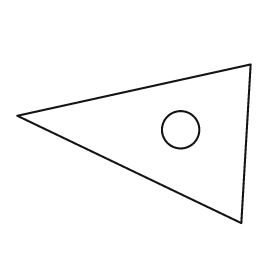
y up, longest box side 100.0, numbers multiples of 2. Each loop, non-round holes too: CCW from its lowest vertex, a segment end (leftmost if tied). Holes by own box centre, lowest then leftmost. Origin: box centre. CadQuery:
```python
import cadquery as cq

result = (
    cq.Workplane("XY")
    .moveTo(46.0, -34.0)
    .lineTo(50.0, 34.0)
    .lineTo(-50.0, 12.0)
    .close()
    .moveTo(20.0, 6.0)
    .circle(8.0)
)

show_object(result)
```